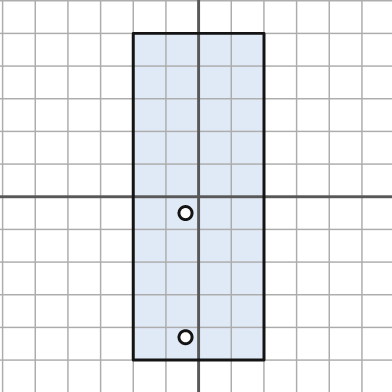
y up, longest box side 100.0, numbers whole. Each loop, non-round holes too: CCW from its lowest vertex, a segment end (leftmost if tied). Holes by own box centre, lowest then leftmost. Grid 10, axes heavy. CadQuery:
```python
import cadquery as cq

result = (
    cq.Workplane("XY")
    .moveTo(-20.0, -50.0)
    .lineTo(20.0, -50.0)
    .lineTo(20.0, 50.0)
    .lineTo(-20.0, 50.0)
    .close()
    .moveTo(-4.0, -43.0)
    .circle(2.0)
    .moveTo(-4.0, -5.0)
    .circle(2.0)
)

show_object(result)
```